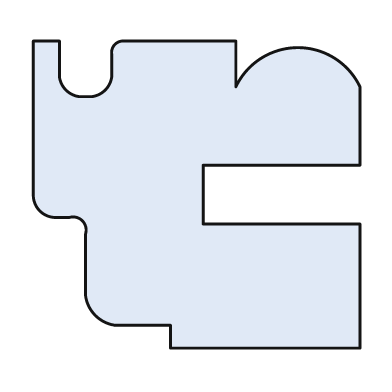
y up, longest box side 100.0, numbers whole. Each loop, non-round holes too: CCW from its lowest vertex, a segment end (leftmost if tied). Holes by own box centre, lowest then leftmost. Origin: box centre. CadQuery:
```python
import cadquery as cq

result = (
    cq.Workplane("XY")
    .moveTo(-8.0, -47.0)
    .lineTo(50.0, -47.0)
    .lineTo(50.0, -9.0)
    .lineTo(2.0, -9.0)
    .lineTo(2.0, 9.0)
    .lineTo(50.0, 9.0)
    .lineTo(50.0, 33.0)
    .threePointArc((31.0, 45.0), (12.0, 33.0))
    .lineTo(12.0, 47.0)
    .lineTo(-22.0, 47.0)
    .threePointArc((-25.0, 46.0), (-26.0, 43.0))
    .lineTo(-26.0, 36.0)
    .threePointArc((-28.0, 32.0), (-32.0, 30.0))
    .lineTo(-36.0, 30.0)
    .threePointArc((-40.0, 32.0), (-42.0, 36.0))
    .lineTo(-42.0, 47.0)
    .lineTo(-50.0, 47.0)
    .lineTo(-50.0, 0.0)
    .threePointArc((-48.0, -5.0), (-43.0, -7.0))
    .lineTo(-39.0, -7.0)
    .threePointArc((-35.0, -8.0), (-34.0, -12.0))
    .lineTo(-34.0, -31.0)
    .threePointArc((-31.0, -37.0), (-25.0, -40.0))
    .lineTo(-8.0, -40.0)
    .close()
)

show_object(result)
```